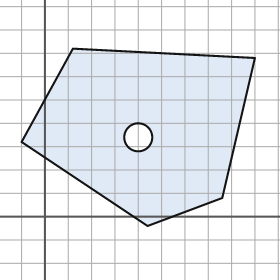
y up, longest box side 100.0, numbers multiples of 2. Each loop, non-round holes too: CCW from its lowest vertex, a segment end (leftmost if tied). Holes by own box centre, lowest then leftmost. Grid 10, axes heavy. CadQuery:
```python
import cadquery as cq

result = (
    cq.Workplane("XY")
    .moveTo(44.0, -4.0)
    .lineTo(76.0, 8.0)
    .lineTo(90.0, 68.0)
    .lineTo(12.0, 72.0)
    .lineTo(-10.0, 32.0)
    .close()
    .moveTo(40.0, 34.0)
    .circle(6.0)
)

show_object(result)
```